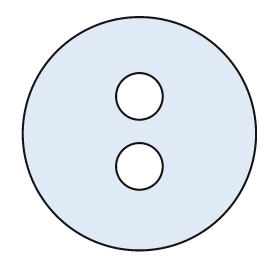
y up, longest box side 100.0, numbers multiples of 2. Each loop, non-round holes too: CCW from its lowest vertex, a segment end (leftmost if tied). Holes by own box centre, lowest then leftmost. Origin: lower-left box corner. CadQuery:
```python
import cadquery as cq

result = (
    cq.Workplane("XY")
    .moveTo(50.0, 50.0)
    .circle(50.0)
    .moveTo(50.0, 36.0)
    .circle(10.0)
    .moveTo(50.0, 66.0)
    .circle(10.0)
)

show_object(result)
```